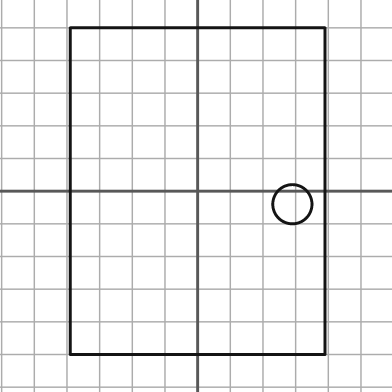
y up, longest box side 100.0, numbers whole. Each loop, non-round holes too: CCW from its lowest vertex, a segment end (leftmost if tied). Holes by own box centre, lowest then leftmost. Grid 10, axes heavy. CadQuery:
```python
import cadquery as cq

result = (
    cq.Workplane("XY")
    .moveTo(-39.0, -50.0)
    .lineTo(39.0, -50.0)
    .lineTo(39.0, 50.0)
    .lineTo(-39.0, 50.0)
    .close()
    .moveTo(29.0, -4.0)
    .circle(6.0)
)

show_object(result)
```